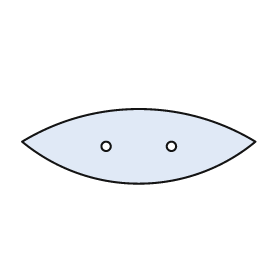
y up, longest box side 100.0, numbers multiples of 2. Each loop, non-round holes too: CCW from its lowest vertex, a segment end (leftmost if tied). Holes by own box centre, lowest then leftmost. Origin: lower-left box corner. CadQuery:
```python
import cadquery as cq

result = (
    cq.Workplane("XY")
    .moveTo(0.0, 18.0)
    .threePointArc((50.0, 0.0), (100.0, 18.0))
    .threePointArc((50.0, 32.0), (0.0, 18.0))
    .close()
    .moveTo(36.0, 16.0)
    .circle(2.0)
    .moveTo(64.0, 16.0)
    .circle(2.0)
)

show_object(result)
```